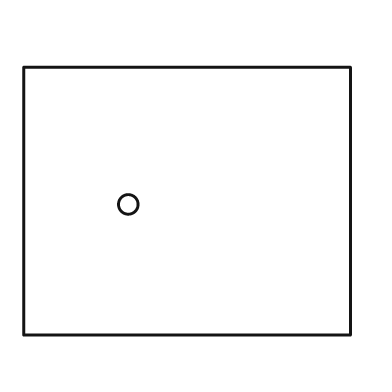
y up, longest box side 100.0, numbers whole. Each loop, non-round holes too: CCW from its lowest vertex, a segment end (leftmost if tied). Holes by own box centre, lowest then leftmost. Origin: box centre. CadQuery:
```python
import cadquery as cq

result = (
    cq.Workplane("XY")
    .moveTo(-50.0, -41.0)
    .lineTo(50.0, -41.0)
    .lineTo(50.0, 41.0)
    .lineTo(-50.0, 41.0)
    .close()
    .moveTo(-18.0, -1.0)
    .circle(3.0)
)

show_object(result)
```